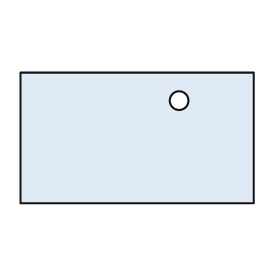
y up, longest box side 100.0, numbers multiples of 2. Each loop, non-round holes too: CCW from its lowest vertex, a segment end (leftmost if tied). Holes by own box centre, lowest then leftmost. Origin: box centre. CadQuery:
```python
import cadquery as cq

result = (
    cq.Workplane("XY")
    .moveTo(-50.0, -28.0)
    .lineTo(50.0, -28.0)
    .lineTo(50.0, 28.0)
    .lineTo(-50.0, 28.0)
    .close()
    .moveTo(18.0, 16.0)
    .circle(4.0)
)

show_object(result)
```